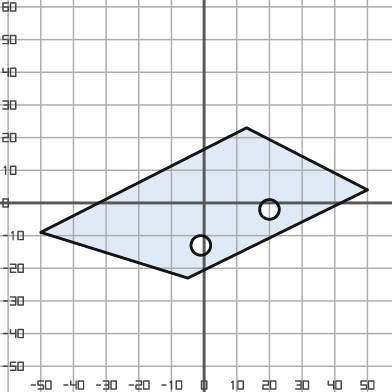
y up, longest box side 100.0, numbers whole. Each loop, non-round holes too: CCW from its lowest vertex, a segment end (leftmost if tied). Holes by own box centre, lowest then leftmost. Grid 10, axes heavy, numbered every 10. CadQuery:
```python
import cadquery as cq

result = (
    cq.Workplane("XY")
    .moveTo(-5.0, -23.0)
    .lineTo(50.0, 4.0)
    .lineTo(13.0, 23.0)
    .lineTo(-50.0, -9.0)
    .close()
    .moveTo(-1.0, -13.0)
    .circle(3.0)
    .moveTo(20.0, -2.0)
    .circle(3.0)
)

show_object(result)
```